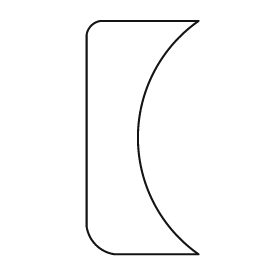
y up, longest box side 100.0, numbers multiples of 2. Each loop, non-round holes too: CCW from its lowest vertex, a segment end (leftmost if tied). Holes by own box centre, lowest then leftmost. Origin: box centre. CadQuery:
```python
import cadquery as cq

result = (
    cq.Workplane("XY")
    .moveTo(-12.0, -50.0)
    .lineTo(24.0, -50.0)
    .threePointArc((-2.0, 0.0), (24.0, 50.0))
    .lineTo(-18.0, 50.0)
    .threePointArc((-22.0, 48.0), (-24.0, 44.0))
    .lineTo(-24.0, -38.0)
    .threePointArc((-20.0, -46.0), (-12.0, -50.0))
    .close()
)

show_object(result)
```